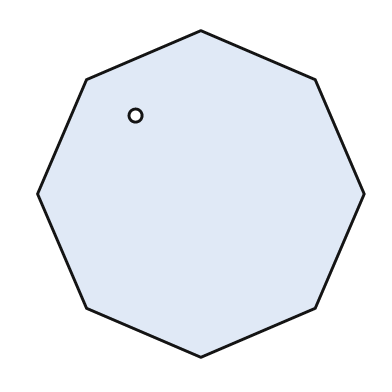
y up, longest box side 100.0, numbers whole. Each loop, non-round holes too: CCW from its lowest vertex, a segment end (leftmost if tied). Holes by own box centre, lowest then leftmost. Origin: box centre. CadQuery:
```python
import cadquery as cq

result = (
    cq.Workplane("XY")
    .moveTo(0.0, -50.0)
    .lineTo(35.0, -35.0)
    .lineTo(50.0, 0.0)
    .lineTo(35.0, 35.0)
    .lineTo(0.0, 50.0)
    .lineTo(-35.0, 35.0)
    .lineTo(-50.0, 0.0)
    .lineTo(-35.0, -35.0)
    .close()
    .moveTo(-20.0, 24.0)
    .circle(2.0)
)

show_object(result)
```